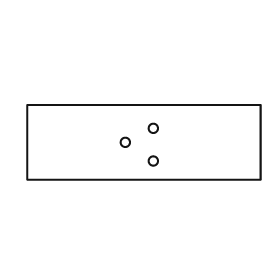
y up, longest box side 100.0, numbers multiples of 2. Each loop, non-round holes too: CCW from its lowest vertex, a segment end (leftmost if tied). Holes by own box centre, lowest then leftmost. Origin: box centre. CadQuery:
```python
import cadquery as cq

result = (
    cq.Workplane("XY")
    .moveTo(-50.0, -16.0)
    .lineTo(50.0, -16.0)
    .lineTo(50.0, 16.0)
    .lineTo(-50.0, 16.0)
    .close()
    .moveTo(4.0, -8.0)
    .circle(2.0)
    .moveTo(-8.0, 0.0)
    .circle(2.0)
    .moveTo(4.0, 6.0)
    .circle(2.0)
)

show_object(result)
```